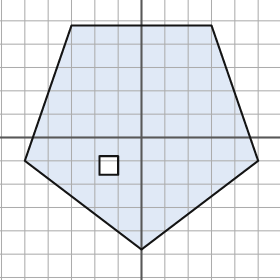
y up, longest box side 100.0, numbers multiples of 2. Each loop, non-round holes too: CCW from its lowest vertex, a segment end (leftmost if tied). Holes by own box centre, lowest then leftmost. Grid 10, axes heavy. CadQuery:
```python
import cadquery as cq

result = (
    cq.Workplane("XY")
    .moveTo(0.0, -48.0)
    .lineTo(50.0, -10.0)
    .lineTo(30.0, 48.0)
    .lineTo(-30.0, 48.0)
    .lineTo(-50.0, -10.0)
    .close()
    .moveTo(-18.0, -16.0)
    .lineTo(-10.0, -16.0)
    .lineTo(-10.0, -8.0)
    .lineTo(-18.0, -8.0)
    .close()
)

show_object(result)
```